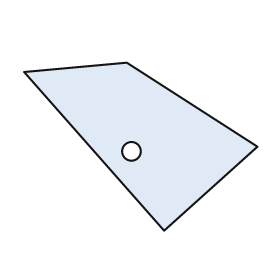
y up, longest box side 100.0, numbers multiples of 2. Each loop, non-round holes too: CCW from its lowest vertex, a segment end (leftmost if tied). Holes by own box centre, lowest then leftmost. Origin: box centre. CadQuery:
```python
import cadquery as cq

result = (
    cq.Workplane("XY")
    .moveTo(10.0, -36.0)
    .lineTo(50.0, 0.0)
    .lineTo(-6.0, 36.0)
    .lineTo(-50.0, 32.0)
    .close()
    .moveTo(-4.0, -2.0)
    .circle(4.0)
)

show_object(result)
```